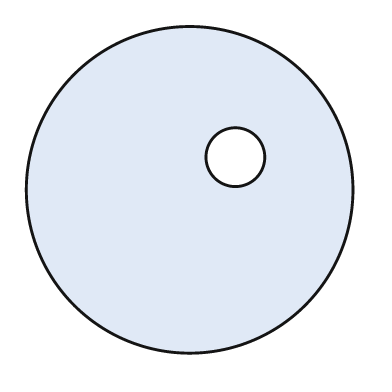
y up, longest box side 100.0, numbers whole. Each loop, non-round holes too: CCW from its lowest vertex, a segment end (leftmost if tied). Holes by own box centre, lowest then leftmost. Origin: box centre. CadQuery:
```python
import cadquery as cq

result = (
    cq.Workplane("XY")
    .moveTo(0.0, 0.0)
    .circle(50.0)
    .moveTo(14.0, 10.0)
    .circle(9.0)
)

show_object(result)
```